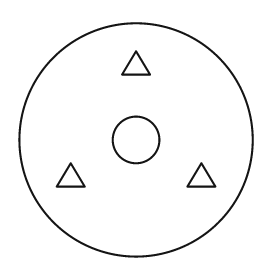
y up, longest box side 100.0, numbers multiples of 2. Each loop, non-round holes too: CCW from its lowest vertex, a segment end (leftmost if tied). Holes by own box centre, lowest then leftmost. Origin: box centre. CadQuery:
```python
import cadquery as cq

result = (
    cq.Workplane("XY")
    .moveTo(0.0, 0.0)
    .circle(50.0)
    .moveTo(-34.0, -20.0)
    .lineTo(-22.0, -20.0)
    .lineTo(-28.0, -10.0)
    .close()
    .moveTo(22.0, -20.0)
    .lineTo(34.0, -20.0)
    .lineTo(28.0, -10.0)
    .close()
    .moveTo(0.0, 0.0)
    .circle(10.0)
    .moveTo(-6.0, 28.0)
    .lineTo(6.0, 28.0)
    .lineTo(0.0, 38.0)
    .close()
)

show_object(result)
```